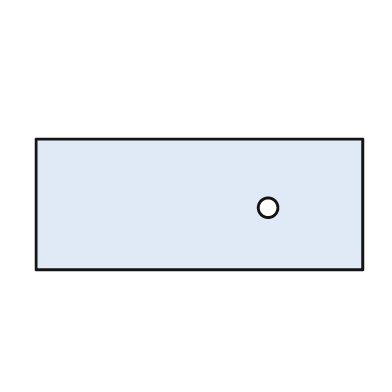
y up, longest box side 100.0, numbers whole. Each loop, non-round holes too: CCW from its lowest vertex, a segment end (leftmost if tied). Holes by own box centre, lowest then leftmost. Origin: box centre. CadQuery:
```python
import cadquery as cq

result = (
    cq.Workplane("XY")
    .moveTo(-50.0, -20.0)
    .lineTo(50.0, -20.0)
    .lineTo(50.0, 20.0)
    .lineTo(-50.0, 20.0)
    .close()
    .moveTo(21.0, -1.0)
    .circle(3.0)
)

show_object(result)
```